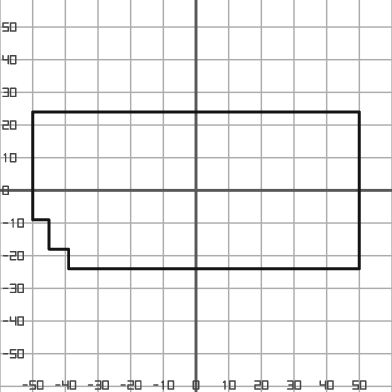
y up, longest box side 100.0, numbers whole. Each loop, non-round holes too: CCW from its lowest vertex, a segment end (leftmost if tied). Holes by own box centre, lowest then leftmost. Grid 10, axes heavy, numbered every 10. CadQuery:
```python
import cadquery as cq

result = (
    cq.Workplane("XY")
    .moveTo(-39.0, -24.0)
    .lineTo(50.0, -24.0)
    .lineTo(50.0, 24.0)
    .lineTo(-50.0, 24.0)
    .lineTo(-50.0, -9.0)
    .lineTo(-45.0, -9.0)
    .lineTo(-45.0, -18.0)
    .lineTo(-39.0, -18.0)
    .close()
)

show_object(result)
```